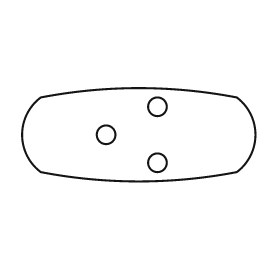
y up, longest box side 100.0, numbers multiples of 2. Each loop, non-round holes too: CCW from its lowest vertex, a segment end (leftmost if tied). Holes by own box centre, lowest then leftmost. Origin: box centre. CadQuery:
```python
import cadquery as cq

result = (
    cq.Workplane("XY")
    .moveTo(-42.0, -16.0)
    .threePointArc((0.0, -20.0), (42.0, -16.0))
    .threePointArc((50.0, 0.0), (42.0, 16.0))
    .threePointArc((0.0, 20.0), (-42.0, 16.0))
    .threePointArc((-50.0, 0.0), (-42.0, -16.0))
    .close()
    .moveTo(8.0, -12.0)
    .circle(4.0)
    .moveTo(-14.0, 0.0)
    .circle(4.0)
    .moveTo(8.0, 12.0)
    .circle(4.0)
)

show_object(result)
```